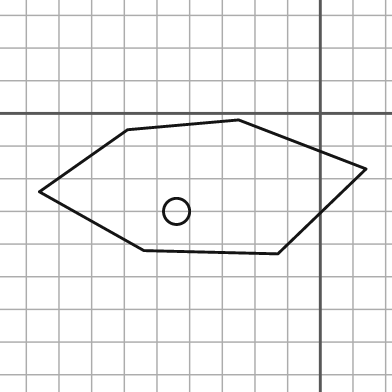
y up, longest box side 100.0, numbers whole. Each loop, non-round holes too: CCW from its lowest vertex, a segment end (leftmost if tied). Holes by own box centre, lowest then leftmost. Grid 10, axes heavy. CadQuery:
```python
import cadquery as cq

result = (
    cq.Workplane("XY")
    .moveTo(-13.0, -43.0)
    .lineTo(14.0, -17.0)
    .lineTo(-25.0, -2.0)
    .lineTo(-59.0, -5.0)
    .lineTo(-86.0, -24.0)
    .lineTo(-54.0, -42.0)
    .close()
    .moveTo(-44.0, -30.0)
    .circle(4.0)
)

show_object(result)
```